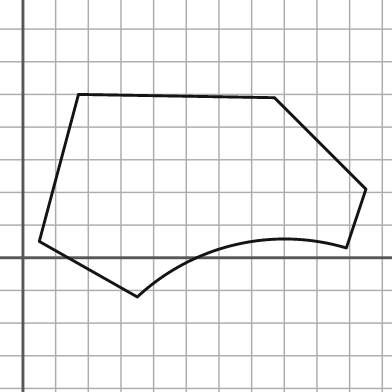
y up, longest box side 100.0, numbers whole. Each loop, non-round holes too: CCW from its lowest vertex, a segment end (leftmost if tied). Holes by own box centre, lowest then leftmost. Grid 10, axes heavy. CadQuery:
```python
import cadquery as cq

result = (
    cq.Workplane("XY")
    .moveTo(35.0, -12.0)
    .threePointArc((65.0, 4.0), (99.0, 3.0))
    .lineTo(105.0, 21.0)
    .lineTo(77.0, 49.0)
    .lineTo(17.0, 50.0)
    .lineTo(5.0, 5.0)
    .close()
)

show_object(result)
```